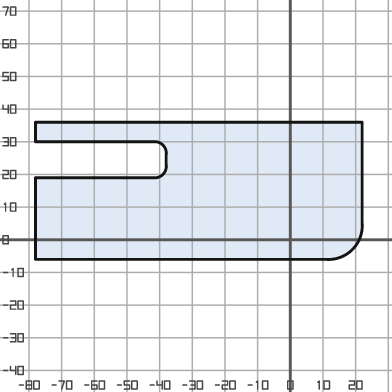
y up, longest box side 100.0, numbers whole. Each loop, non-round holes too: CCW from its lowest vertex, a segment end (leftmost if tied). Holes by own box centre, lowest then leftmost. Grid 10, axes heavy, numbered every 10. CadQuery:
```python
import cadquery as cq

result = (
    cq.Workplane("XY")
    .moveTo(-78.0, -6.0)
    .lineTo(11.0, -6.0)
    .threePointArc((19.0, -3.0), (22.0, 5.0))
    .lineTo(22.0, 36.0)
    .lineTo(-78.0, 36.0)
    .lineTo(-78.0, 30.0)
    .lineTo(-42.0, 30.0)
    .threePointArc((-39.0, 29.0), (-38.0, 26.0))
    .lineTo(-38.0, 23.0)
    .threePointArc((-39.0, 20.0), (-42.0, 19.0))
    .lineTo(-78.0, 19.0)
    .close()
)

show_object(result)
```